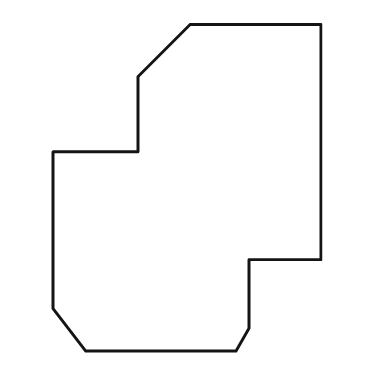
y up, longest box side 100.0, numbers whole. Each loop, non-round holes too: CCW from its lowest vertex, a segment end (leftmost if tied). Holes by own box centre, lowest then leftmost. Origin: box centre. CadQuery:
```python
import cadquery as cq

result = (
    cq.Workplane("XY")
    .moveTo(-31.0, -50.0)
    .lineTo(15.0, -50.0)
    .lineTo(19.0, -43.0)
    .lineTo(19.0, -22.0)
    .lineTo(41.0, -22.0)
    .lineTo(41.0, 50.0)
    .lineTo(1.0, 50.0)
    .lineTo(-15.0, 34.0)
    .lineTo(-15.0, 11.0)
    .lineTo(-41.0, 11.0)
    .lineTo(-41.0, -37.0)
    .close()
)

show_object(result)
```